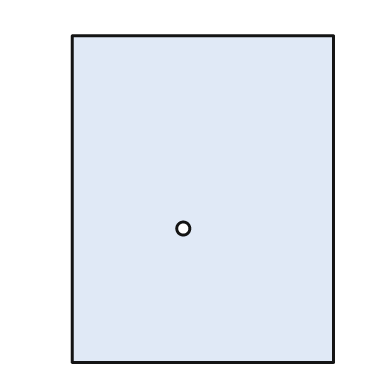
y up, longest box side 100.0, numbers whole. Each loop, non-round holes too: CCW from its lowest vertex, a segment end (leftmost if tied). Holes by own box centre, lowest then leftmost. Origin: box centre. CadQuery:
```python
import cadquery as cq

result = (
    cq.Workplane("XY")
    .moveTo(-40.0, -50.0)
    .lineTo(40.0, -50.0)
    .lineTo(40.0, 50.0)
    .lineTo(-40.0, 50.0)
    .close()
    .moveTo(-6.0, -9.0)
    .circle(2.0)
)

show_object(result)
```